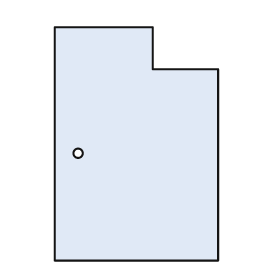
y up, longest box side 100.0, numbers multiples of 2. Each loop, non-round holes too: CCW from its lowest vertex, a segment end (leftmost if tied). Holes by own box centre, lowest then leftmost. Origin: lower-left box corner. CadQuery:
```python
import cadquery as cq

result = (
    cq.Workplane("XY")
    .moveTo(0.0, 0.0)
    .lineTo(70.0, 0.0)
    .lineTo(70.0, 82.0)
    .lineTo(42.0, 82.0)
    .lineTo(42.0, 100.0)
    .lineTo(0.0, 100.0)
    .close()
    .moveTo(10.0, 46.0)
    .circle(2.0)
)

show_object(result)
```